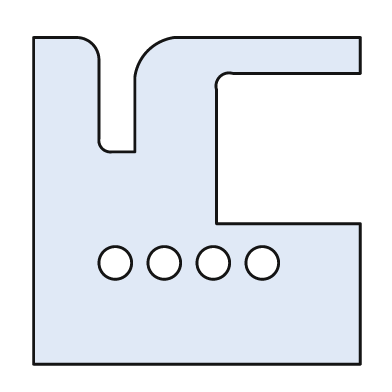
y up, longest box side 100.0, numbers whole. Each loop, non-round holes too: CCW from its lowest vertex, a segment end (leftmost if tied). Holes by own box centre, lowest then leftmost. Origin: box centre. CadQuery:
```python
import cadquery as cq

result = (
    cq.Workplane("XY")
    .moveTo(-50.0, -50.0)
    .lineTo(50.0, -50.0)
    .lineTo(50.0, -7.0)
    .lineTo(6.0, -7.0)
    .lineTo(6.0, 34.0)
    .threePointArc((7.0, 38.0), (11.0, 39.0))
    .lineTo(50.0, 39.0)
    .lineTo(50.0, 50.0)
    .lineTo(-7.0, 50.0)
    .threePointArc((-15.0, 46.0), (-19.0, 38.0))
    .lineTo(-19.0, 15.0)
    .lineTo(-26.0, 15.0)
    .threePointArc((-29.0, 16.0), (-30.0, 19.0))
    .lineTo(-30.0, 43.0)
    .threePointArc((-32.0, 48.0), (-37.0, 50.0))
    .lineTo(-50.0, 50.0)
    .close()
    .moveTo(-25.0, -19.0)
    .circle(5.0)
    .moveTo(-10.0, -19.0)
    .circle(5.0)
    .moveTo(5.0, -19.0)
    .circle(5.0)
    .moveTo(20.0, -19.0)
    .circle(5.0)
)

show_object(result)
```